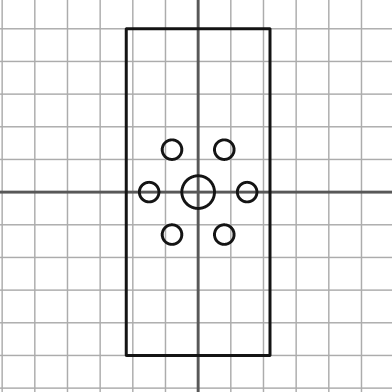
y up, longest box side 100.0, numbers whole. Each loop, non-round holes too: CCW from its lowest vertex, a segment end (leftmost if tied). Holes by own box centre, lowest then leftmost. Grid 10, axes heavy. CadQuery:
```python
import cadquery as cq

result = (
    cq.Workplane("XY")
    .moveTo(-22.0, -50.0)
    .lineTo(22.0, -50.0)
    .lineTo(22.0, 50.0)
    .lineTo(-22.0, 50.0)
    .close()
    .moveTo(-8.0, -13.0)
    .circle(3.0)
    .moveTo(8.0, -13.0)
    .circle(3.0)
    .moveTo(-15.0, 0.0)
    .circle(3.0)
    .moveTo(0.0, 0.0)
    .circle(5.0)
    .moveTo(15.0, 0.0)
    .circle(3.0)
    .moveTo(-8.0, 13.0)
    .circle(3.0)
    .moveTo(8.0, 13.0)
    .circle(3.0)
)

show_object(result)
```